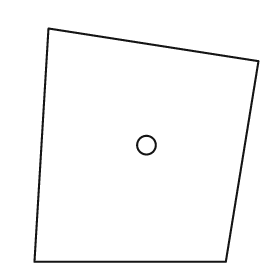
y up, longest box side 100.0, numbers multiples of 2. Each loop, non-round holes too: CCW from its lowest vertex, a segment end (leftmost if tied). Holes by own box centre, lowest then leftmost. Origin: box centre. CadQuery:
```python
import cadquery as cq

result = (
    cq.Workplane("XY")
    .moveTo(-48.0, -50.0)
    .lineTo(34.0, -50.0)
    .lineTo(48.0, 36.0)
    .lineTo(-42.0, 50.0)
    .close()
    .moveTo(0.0, 0.0)
    .circle(4.0)
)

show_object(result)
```